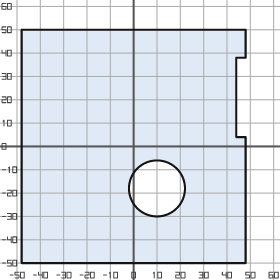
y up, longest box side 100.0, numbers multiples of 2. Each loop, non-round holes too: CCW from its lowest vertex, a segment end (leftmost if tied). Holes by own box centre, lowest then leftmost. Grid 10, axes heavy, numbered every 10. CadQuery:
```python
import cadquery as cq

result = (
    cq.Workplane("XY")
    .moveTo(-48.0, -50.0)
    .lineTo(48.0, -50.0)
    .lineTo(48.0, 4.0)
    .lineTo(44.0, 4.0)
    .lineTo(44.0, 38.0)
    .lineTo(48.0, 38.0)
    .lineTo(48.0, 50.0)
    .lineTo(-48.0, 50.0)
    .close()
    .moveTo(10.0, -18.0)
    .circle(12.0)
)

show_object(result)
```